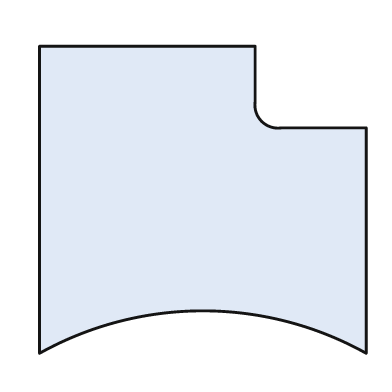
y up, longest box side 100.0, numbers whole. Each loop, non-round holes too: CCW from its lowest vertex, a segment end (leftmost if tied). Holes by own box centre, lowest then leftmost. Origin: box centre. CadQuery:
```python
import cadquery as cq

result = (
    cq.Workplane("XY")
    .moveTo(-50.0, -47.0)
    .threePointArc((0.0, -34.0), (50.0, -47.0))
    .lineTo(50.0, 22.0)
    .lineTo(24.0, 22.0)
    .threePointArc((18.0, 24.0), (16.0, 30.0))
    .lineTo(16.0, 47.0)
    .lineTo(-50.0, 47.0)
    .close()
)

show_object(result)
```